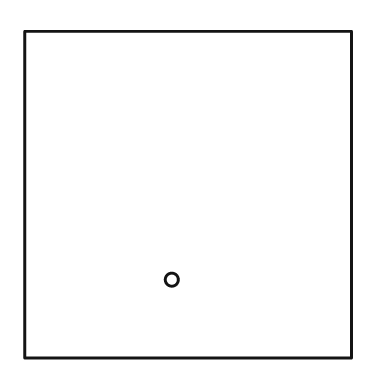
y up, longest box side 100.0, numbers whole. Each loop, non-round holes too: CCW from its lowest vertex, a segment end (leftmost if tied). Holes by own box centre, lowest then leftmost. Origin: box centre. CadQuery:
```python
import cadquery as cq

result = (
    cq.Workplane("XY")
    .moveTo(-50.0, -50.0)
    .lineTo(50.0, -50.0)
    .lineTo(50.0, 50.0)
    .lineTo(-50.0, 50.0)
    .close()
    .moveTo(-5.0, -26.0)
    .circle(2.0)
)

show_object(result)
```